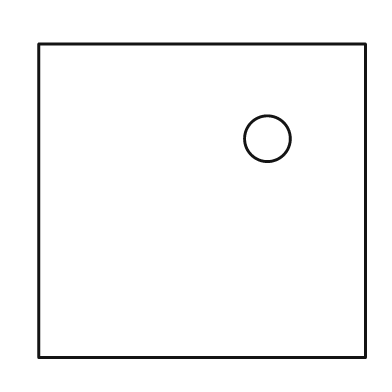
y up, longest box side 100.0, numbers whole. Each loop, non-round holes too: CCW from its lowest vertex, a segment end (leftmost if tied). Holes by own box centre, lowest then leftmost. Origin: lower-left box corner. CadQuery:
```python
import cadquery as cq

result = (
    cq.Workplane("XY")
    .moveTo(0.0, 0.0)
    .lineTo(100.0, 0.0)
    .lineTo(100.0, 96.0)
    .lineTo(0.0, 96.0)
    .close()
    .moveTo(70.0, 67.0)
    .circle(7.0)
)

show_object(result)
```